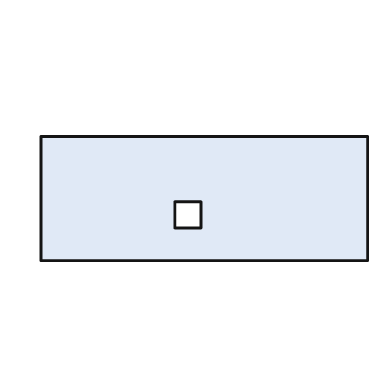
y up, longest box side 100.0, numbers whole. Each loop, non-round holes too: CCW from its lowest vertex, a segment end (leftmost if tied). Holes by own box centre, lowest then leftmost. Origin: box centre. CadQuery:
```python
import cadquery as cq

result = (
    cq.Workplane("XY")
    .moveTo(-50.0, -19.0)
    .lineTo(50.0, -19.0)
    .lineTo(50.0, 19.0)
    .lineTo(-50.0, 19.0)
    .close()
    .moveTo(-9.0, -9.0)
    .lineTo(-1.0, -9.0)
    .lineTo(-1.0, -1.0)
    .lineTo(-9.0, -1.0)
    .close()
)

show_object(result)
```